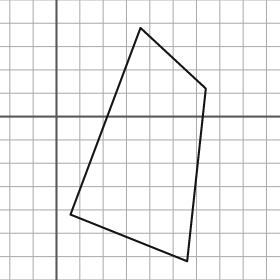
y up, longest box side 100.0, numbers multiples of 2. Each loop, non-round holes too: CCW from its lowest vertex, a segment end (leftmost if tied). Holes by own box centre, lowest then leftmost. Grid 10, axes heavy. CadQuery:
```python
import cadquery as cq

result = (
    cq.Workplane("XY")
    .moveTo(56.0, -62.0)
    .lineTo(64.0, 12.0)
    .lineTo(36.0, 38.0)
    .lineTo(6.0, -42.0)
    .close()
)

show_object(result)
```